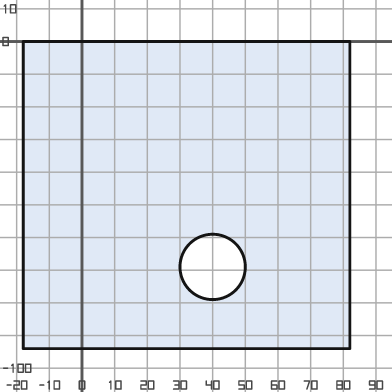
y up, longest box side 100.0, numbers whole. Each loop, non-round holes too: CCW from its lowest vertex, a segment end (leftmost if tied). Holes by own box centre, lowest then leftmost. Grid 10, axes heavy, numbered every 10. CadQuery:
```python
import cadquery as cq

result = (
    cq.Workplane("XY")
    .moveTo(-18.0, -94.0)
    .lineTo(82.0, -94.0)
    .lineTo(82.0, 0.0)
    .lineTo(-18.0, 0.0)
    .close()
    .moveTo(40.0, -69.0)
    .circle(10.0)
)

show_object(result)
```